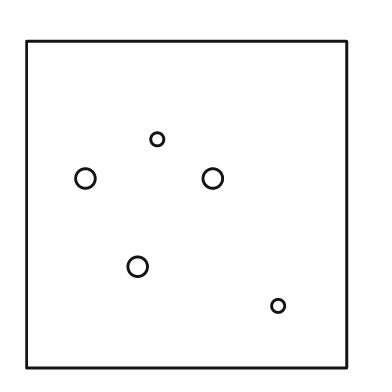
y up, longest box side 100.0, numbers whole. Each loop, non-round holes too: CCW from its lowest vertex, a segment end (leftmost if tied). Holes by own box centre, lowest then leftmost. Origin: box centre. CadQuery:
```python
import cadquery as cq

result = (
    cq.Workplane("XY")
    .moveTo(-49.0, -50.0)
    .lineTo(49.0, -50.0)
    .lineTo(49.0, 50.0)
    .lineTo(-49.0, 50.0)
    .close()
    .moveTo(28.0, -31.0)
    .circle(2.0)
    .moveTo(-15.0, -19.0)
    .circle(3.0)
    .moveTo(-31.0, 8.0)
    .circle(3.0)
    .moveTo(8.0, 8.0)
    .circle(3.0)
    .moveTo(-9.0, 20.0)
    .circle(2.0)
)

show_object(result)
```